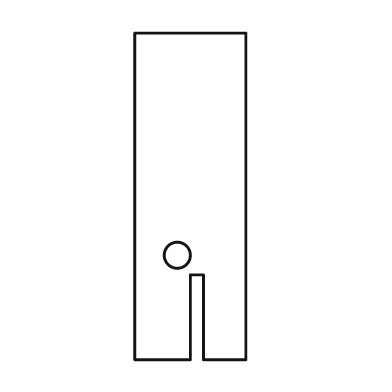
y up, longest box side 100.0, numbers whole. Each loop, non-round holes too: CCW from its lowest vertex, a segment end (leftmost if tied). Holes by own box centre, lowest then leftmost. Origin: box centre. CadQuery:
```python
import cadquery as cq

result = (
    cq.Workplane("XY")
    .moveTo(-17.0, -50.0)
    .lineTo(0.0, -50.0)
    .lineTo(0.0, -24.0)
    .lineTo(4.0, -24.0)
    .lineTo(4.0, -50.0)
    .lineTo(17.0, -50.0)
    .lineTo(17.0, 50.0)
    .lineTo(-17.0, 50.0)
    .close()
    .moveTo(-4.0, -18.0)
    .circle(4.0)
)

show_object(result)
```